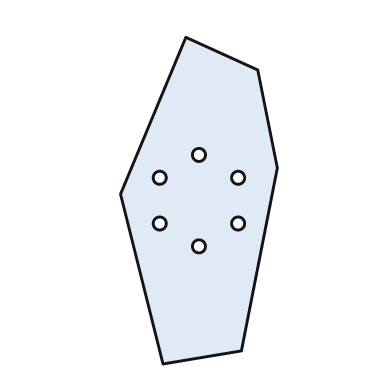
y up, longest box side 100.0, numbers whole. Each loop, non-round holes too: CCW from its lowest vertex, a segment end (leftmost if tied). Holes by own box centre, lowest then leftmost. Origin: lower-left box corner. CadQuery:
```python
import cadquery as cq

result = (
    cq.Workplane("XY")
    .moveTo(13.0, 0.0)
    .lineTo(37.0, 4.0)
    .lineTo(48.0, 60.0)
    .lineTo(42.0, 90.0)
    .lineTo(20.0, 100.0)
    .lineTo(0.0, 52.0)
    .close()
    .moveTo(24.0, 36.0)
    .circle(2.0)
    .moveTo(12.0, 43.0)
    .circle(2.0)
    .moveTo(36.0, 43.0)
    .circle(2.0)
    .moveTo(12.0, 57.0)
    .circle(2.0)
    .moveTo(36.0, 57.0)
    .circle(2.0)
    .moveTo(24.0, 64.0)
    .circle(2.0)
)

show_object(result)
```